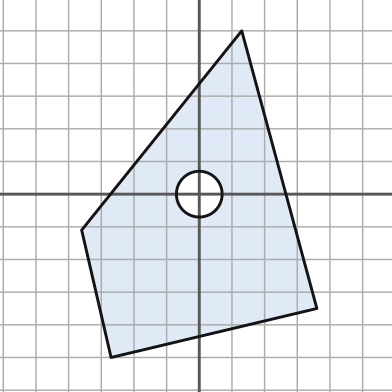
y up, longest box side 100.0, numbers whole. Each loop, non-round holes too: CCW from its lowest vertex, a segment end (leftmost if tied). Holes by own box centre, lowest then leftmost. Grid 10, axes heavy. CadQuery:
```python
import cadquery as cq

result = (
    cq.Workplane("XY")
    .moveTo(-27.0, -50.0)
    .lineTo(36.0, -35.0)
    .lineTo(13.0, 50.0)
    .lineTo(-36.0, -11.0)
    .close()
    .moveTo(0.0, 0.0)
    .circle(7.0)
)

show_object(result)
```